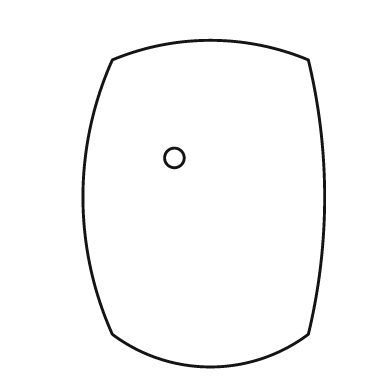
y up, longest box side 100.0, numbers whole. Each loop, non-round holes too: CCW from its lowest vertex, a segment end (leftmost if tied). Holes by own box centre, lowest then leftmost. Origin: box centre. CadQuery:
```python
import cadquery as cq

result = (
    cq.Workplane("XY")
    .moveTo(-28.0, -40.0)
    .threePointArc((2.0, -50.0), (32.0, -40.0))
    .threePointArc((37.0, 2.0), (32.0, 44.0))
    .threePointArc((2.0, 50.0), (-28.0, 44.0))
    .threePointArc((-37.0, 2.0), (-28.0, -40.0))
    .close()
    .moveTo(-9.0, 14.0)
    .circle(3.0)
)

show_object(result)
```